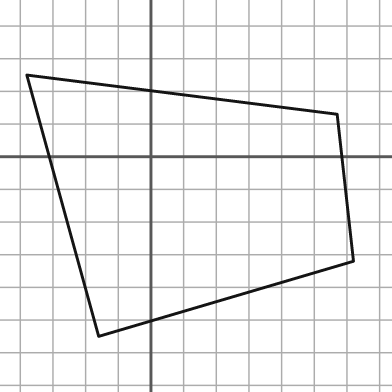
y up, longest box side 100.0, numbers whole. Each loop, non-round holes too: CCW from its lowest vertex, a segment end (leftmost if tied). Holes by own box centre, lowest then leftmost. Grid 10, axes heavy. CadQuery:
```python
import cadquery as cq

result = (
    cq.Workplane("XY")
    .moveTo(-16.0, -55.0)
    .lineTo(62.0, -32.0)
    .lineTo(57.0, 13.0)
    .lineTo(-38.0, 25.0)
    .close()
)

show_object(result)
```